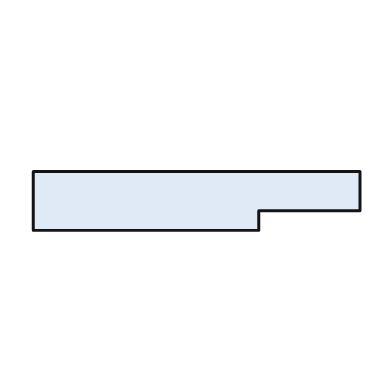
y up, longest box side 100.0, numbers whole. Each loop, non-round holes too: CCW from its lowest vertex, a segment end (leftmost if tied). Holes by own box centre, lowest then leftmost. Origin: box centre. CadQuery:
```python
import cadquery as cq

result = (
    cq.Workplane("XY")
    .moveTo(-50.0, -9.0)
    .lineTo(19.0, -9.0)
    .lineTo(19.0, -3.0)
    .lineTo(50.0, -3.0)
    .lineTo(50.0, 9.0)
    .lineTo(-50.0, 9.0)
    .close()
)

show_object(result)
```